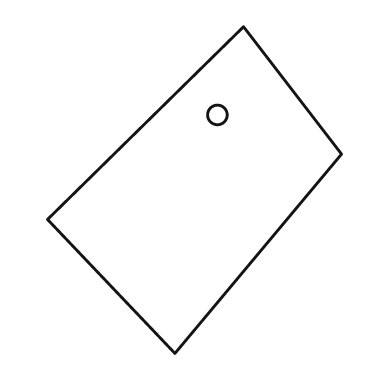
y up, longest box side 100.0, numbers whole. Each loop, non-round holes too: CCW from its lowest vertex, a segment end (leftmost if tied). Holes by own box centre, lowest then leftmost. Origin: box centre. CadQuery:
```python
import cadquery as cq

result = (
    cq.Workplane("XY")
    .moveTo(-6.0, -50.0)
    .lineTo(45.0, 11.0)
    .lineTo(15.0, 50.0)
    .lineTo(-45.0, -9.0)
    .close()
    .moveTo(7.0, 23.0)
    .circle(3.0)
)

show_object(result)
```